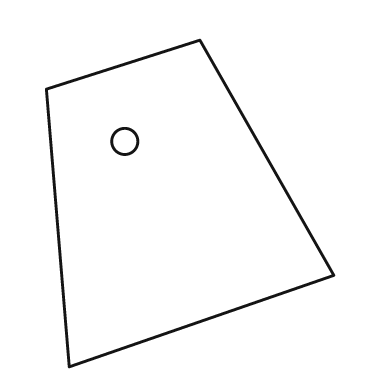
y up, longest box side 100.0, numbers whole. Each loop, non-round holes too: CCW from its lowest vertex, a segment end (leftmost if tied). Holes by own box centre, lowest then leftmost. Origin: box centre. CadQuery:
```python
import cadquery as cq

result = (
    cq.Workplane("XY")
    .moveTo(-37.0, -50.0)
    .lineTo(44.0, -22.0)
    .lineTo(3.0, 50.0)
    .lineTo(-44.0, 35.0)
    .close()
    .moveTo(-20.0, 19.0)
    .circle(4.0)
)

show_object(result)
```